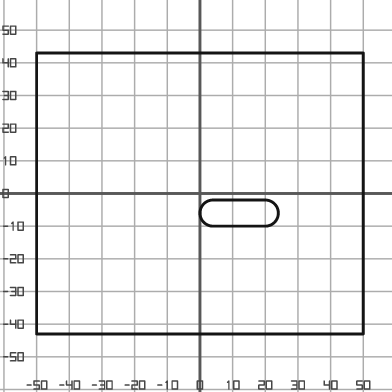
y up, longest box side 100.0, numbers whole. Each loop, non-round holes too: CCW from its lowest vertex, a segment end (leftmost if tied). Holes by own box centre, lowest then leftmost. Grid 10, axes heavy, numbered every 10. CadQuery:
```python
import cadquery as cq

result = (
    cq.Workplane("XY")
    .moveTo(-50.0, -43.0)
    .lineTo(50.0, -43.0)
    .lineTo(50.0, 43.0)
    .lineTo(-50.0, 43.0)
    .close()
    .moveTo(4.0, -10.0)
    .lineTo(20.0, -10.0)
    .threePointArc((24.0, -6.0), (20.0, -2.0))
    .lineTo(4.0, -2.0)
    .threePointArc((0.0, -6.0), (4.0, -10.0))
    .close()
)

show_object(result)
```